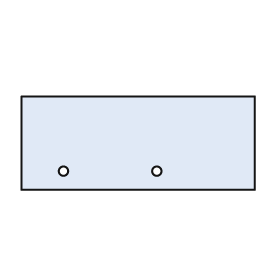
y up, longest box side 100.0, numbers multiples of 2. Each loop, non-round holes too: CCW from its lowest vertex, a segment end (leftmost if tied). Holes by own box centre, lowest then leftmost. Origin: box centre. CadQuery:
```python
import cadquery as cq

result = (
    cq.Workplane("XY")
    .moveTo(-50.0, -20.0)
    .lineTo(50.0, -20.0)
    .lineTo(50.0, 20.0)
    .lineTo(-50.0, 20.0)
    .close()
    .moveTo(-32.0, -12.0)
    .circle(2.0)
    .moveTo(8.0, -12.0)
    .circle(2.0)
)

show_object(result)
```